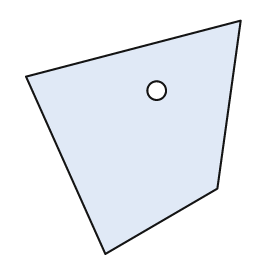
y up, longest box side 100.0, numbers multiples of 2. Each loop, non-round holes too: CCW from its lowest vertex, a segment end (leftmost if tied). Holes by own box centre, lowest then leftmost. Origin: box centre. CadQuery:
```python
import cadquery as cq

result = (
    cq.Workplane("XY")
    .moveTo(-12.0, -50.0)
    .lineTo(36.0, -22.0)
    .lineTo(46.0, 50.0)
    .lineTo(-46.0, 26.0)
    .close()
    .moveTo(10.0, 20.0)
    .circle(4.0)
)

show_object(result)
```